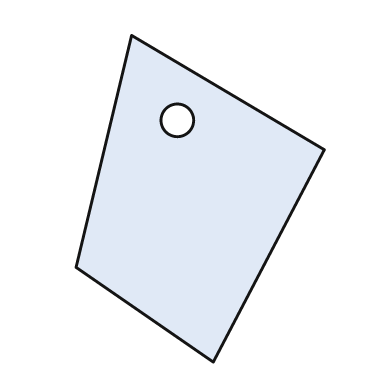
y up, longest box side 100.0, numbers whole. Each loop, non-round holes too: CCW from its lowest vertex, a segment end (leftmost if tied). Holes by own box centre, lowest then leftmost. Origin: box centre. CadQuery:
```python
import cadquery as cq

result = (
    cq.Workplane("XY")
    .moveTo(4.0, -50.0)
    .lineTo(38.0, 15.0)
    .lineTo(-21.0, 50.0)
    .lineTo(-38.0, -21.0)
    .close()
    .moveTo(-7.0, 24.0)
    .circle(5.0)
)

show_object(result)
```